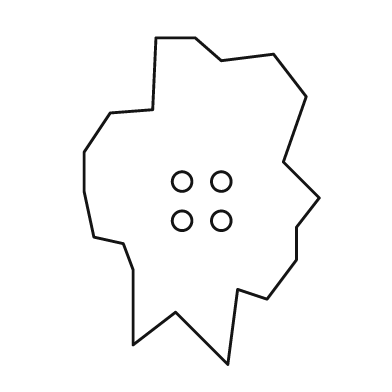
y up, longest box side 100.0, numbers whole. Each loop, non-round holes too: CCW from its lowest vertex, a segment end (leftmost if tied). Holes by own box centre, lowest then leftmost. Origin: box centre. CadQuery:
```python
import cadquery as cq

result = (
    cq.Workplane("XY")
    .moveTo(8.0, -50.0)
    .lineTo(11.0, -27.0)
    .lineTo(20.0, -30.0)
    .lineTo(29.0, -18.0)
    .lineTo(29.0, -8.0)
    .lineTo(36.0, 1.0)
    .lineTo(25.0, 12.0)
    .lineTo(32.0, 32.0)
    .lineTo(22.0, 45.0)
    .lineTo(6.0, 43.0)
    .lineTo(-2.0, 50.0)
    .lineTo(-14.0, 50.0)
    .lineTo(-15.0, 28.0)
    .lineTo(-28.0, 27.0)
    .lineTo(-36.0, 15.0)
    .lineTo(-36.0, 3.0)
    .lineTo(-33.0, -11.0)
    .lineTo(-24.0, -13.0)
    .lineTo(-21.0, -21.0)
    .lineTo(-21.0, -44.0)
    .lineTo(-8.0, -34.0)
    .close()
    .moveTo(-6.0, -6.0)
    .circle(3.0)
    .moveTo(6.0, -6.0)
    .circle(3.0)
    .moveTo(-6.0, 6.0)
    .circle(3.0)
    .moveTo(6.0, 6.0)
    .circle(3.0)
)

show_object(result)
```